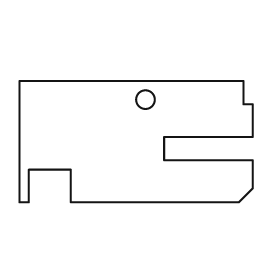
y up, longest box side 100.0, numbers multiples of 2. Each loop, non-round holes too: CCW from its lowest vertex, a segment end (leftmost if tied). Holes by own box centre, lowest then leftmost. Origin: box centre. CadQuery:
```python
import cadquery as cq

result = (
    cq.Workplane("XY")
    .moveTo(-50.0, -26.0)
    .lineTo(-46.0, -26.0)
    .lineTo(-46.0, -12.0)
    .lineTo(-28.0, -12.0)
    .lineTo(-28.0, -26.0)
    .lineTo(44.0, -26.0)
    .lineTo(50.0, -20.0)
    .lineTo(50.0, -8.0)
    .lineTo(12.0, -8.0)
    .lineTo(12.0, 2.0)
    .lineTo(50.0, 2.0)
    .lineTo(50.0, 16.0)
    .lineTo(46.0, 16.0)
    .lineTo(46.0, 26.0)
    .lineTo(-50.0, 26.0)
    .close()
    .moveTo(4.0, 18.0)
    .circle(4.0)
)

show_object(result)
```